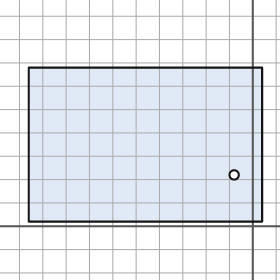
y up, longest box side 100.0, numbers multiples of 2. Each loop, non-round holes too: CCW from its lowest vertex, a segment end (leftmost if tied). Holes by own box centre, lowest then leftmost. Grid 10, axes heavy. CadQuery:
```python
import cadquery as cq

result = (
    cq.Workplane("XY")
    .moveTo(-96.0, 2.0)
    .lineTo(4.0, 2.0)
    .lineTo(4.0, 68.0)
    .lineTo(-96.0, 68.0)
    .close()
    .moveTo(-8.0, 22.0)
    .circle(2.0)
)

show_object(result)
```